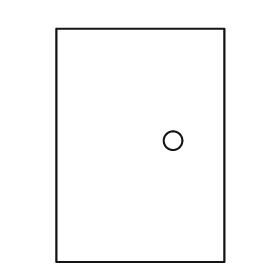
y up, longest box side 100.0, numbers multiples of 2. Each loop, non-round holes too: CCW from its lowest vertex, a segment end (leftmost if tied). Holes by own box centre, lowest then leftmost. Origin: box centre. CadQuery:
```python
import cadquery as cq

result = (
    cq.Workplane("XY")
    .moveTo(-36.0, -50.0)
    .lineTo(36.0, -50.0)
    .lineTo(36.0, 50.0)
    .lineTo(-36.0, 50.0)
    .close()
    .moveTo(14.0, 2.0)
    .circle(4.0)
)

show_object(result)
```